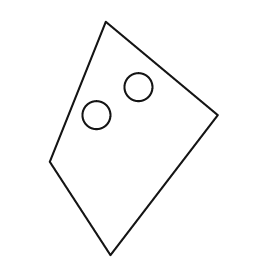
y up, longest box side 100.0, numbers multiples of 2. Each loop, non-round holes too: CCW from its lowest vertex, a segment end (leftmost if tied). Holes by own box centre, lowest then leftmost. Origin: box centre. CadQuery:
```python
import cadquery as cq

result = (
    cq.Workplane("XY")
    .moveTo(-10.0, -50.0)
    .lineTo(36.0, 10.0)
    .lineTo(-12.0, 50.0)
    .lineTo(-36.0, -10.0)
    .close()
    .moveTo(-16.0, 10.0)
    .circle(6.0)
    .moveTo(2.0, 22.0)
    .circle(6.0)
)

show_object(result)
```